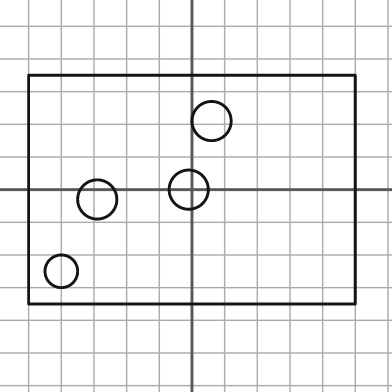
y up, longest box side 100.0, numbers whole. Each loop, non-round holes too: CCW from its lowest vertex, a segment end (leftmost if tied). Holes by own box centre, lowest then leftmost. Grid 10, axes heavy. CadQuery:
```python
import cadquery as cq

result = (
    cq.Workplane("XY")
    .moveTo(-50.0, -35.0)
    .lineTo(50.0, -35.0)
    .lineTo(50.0, 35.0)
    .lineTo(-50.0, 35.0)
    .close()
    .moveTo(-40.0, -25.0)
    .circle(5.0)
    .moveTo(-29.0, -3.0)
    .circle(6.0)
    .moveTo(-1.0, 0.0)
    .circle(6.0)
    .moveTo(6.0, 21.0)
    .circle(6.0)
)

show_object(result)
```